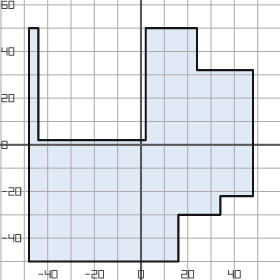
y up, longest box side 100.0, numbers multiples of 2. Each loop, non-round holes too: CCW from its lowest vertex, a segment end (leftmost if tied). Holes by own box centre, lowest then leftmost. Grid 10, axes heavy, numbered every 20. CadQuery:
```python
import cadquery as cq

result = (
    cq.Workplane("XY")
    .moveTo(-48.0, -50.0)
    .lineTo(16.0, -50.0)
    .lineTo(16.0, -30.0)
    .lineTo(34.0, -30.0)
    .lineTo(34.0, -22.0)
    .lineTo(48.0, -22.0)
    .lineTo(48.0, 32.0)
    .lineTo(24.0, 32.0)
    .lineTo(24.0, 50.0)
    .lineTo(2.0, 50.0)
    .lineTo(2.0, 2.0)
    .lineTo(-44.0, 2.0)
    .lineTo(-44.0, 50.0)
    .lineTo(-48.0, 50.0)
    .close()
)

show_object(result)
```